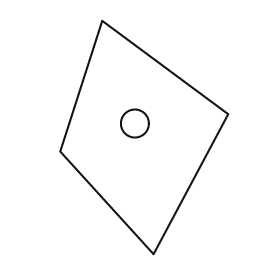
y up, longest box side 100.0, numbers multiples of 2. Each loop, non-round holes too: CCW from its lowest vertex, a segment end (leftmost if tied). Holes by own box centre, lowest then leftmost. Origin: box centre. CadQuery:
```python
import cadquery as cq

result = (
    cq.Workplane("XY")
    .moveTo(4.0, -50.0)
    .lineTo(36.0, 10.0)
    .lineTo(-18.0, 50.0)
    .lineTo(-36.0, -6.0)
    .close()
    .moveTo(-4.0, 6.0)
    .circle(6.0)
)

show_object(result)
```